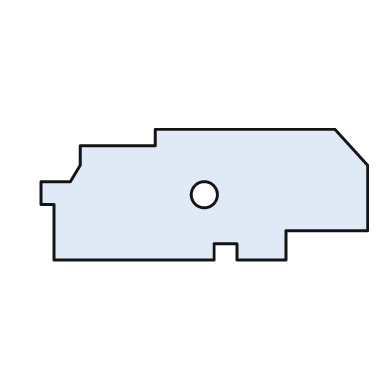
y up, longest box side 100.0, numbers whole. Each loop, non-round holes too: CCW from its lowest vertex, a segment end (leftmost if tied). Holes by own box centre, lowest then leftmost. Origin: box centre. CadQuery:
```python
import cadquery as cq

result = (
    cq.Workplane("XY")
    .moveTo(-46.0, -20.0)
    .lineTo(3.0, -20.0)
    .lineTo(3.0, -15.0)
    .lineTo(10.0, -15.0)
    .lineTo(10.0, -20.0)
    .lineTo(25.0, -20.0)
    .lineTo(25.0, -11.0)
    .lineTo(50.0, -11.0)
    .lineTo(50.0, 9.0)
    .lineTo(40.0, 20.0)
    .lineTo(-15.0, 20.0)
    .lineTo(-15.0, 15.0)
    .lineTo(-38.0, 15.0)
    .lineTo(-38.0, 9.0)
    .lineTo(-41.0, 4.0)
    .lineTo(-50.0, 4.0)
    .lineTo(-50.0, -3.0)
    .lineTo(-46.0, -3.0)
    .close()
    .moveTo(0.0, 0.0)
    .circle(4.0)
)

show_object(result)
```